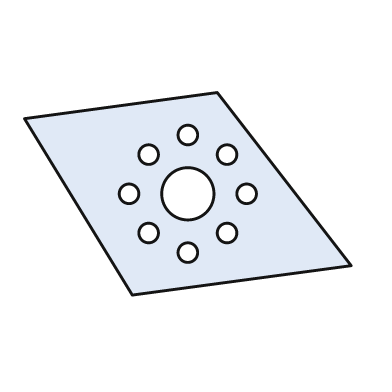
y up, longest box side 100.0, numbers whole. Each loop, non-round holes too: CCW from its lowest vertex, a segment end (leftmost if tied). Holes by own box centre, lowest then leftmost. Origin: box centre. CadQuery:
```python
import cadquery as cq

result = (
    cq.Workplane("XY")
    .moveTo(-17.0, -31.0)
    .lineTo(50.0, -22.0)
    .lineTo(9.0, 31.0)
    .lineTo(-50.0, 23.0)
    .close()
    .moveTo(0.0, -18.0)
    .circle(3.0)
    .moveTo(-12.0, -12.0)
    .circle(3.0)
    .moveTo(12.0, -12.0)
    .circle(3.0)
    .moveTo(-18.0, 0.0)
    .circle(3.0)
    .moveTo(0.0, 0.0)
    .circle(8.0)
    .moveTo(18.0, 0.0)
    .circle(3.0)
    .moveTo(-12.0, 12.0)
    .circle(3.0)
    .moveTo(12.0, 12.0)
    .circle(3.0)
    .moveTo(0.0, 18.0)
    .circle(3.0)
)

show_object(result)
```